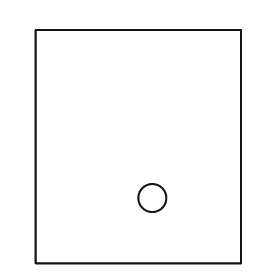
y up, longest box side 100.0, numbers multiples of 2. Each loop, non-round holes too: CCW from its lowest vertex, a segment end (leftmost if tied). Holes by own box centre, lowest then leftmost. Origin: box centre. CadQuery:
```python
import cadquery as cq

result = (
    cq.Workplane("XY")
    .moveTo(-44.0, -50.0)
    .lineTo(44.0, -50.0)
    .lineTo(44.0, 50.0)
    .lineTo(-44.0, 50.0)
    .close()
    .moveTo(6.0, -22.0)
    .circle(6.0)
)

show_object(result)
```